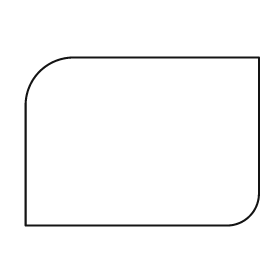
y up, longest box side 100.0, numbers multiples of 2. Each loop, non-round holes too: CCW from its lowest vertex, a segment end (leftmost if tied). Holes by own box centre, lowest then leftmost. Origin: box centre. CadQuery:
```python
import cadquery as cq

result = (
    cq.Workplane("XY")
    .moveTo(-50.0, -36.0)
    .lineTo(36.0, -36.0)
    .threePointArc((46.0, -32.0), (50.0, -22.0))
    .lineTo(50.0, 36.0)
    .lineTo(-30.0, 36.0)
    .threePointArc((-44.0, 30.0), (-50.0, 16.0))
    .close()
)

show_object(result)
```